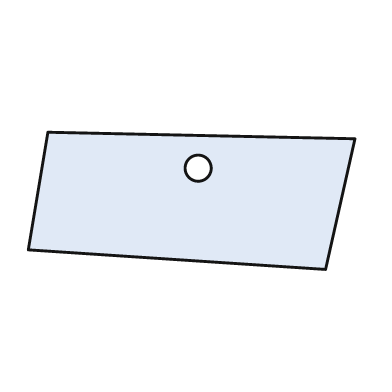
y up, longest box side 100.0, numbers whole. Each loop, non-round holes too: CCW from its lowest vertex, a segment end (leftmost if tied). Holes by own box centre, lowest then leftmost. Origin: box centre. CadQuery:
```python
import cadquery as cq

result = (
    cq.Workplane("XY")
    .moveTo(41.0, -21.0)
    .lineTo(50.0, 19.0)
    .lineTo(-44.0, 21.0)
    .lineTo(-50.0, -15.0)
    .close()
    .moveTo(2.0, 10.0)
    .circle(4.0)
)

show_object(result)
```